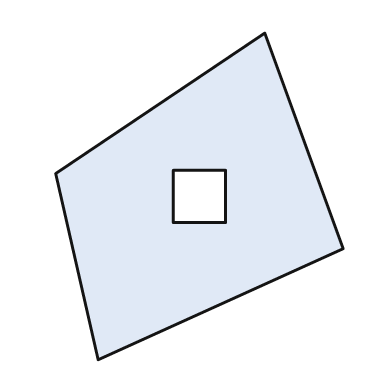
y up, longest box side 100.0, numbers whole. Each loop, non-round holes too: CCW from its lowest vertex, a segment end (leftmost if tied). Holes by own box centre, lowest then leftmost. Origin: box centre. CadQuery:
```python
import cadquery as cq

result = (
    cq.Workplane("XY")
    .moveTo(-31.0, -50.0)
    .lineTo(44.0, -16.0)
    .lineTo(20.0, 50.0)
    .lineTo(-44.0, 7.0)
    .close()
    .moveTo(-8.0, -8.0)
    .lineTo(8.0, -8.0)
    .lineTo(8.0, 8.0)
    .lineTo(-8.0, 8.0)
    .close()
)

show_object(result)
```